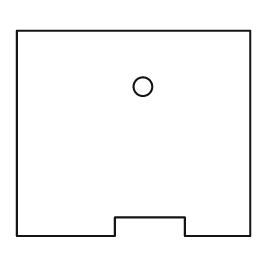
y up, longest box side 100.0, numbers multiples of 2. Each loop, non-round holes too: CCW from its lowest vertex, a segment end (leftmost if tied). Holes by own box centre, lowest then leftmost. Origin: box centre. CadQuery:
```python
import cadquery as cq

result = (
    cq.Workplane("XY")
    .moveTo(-50.0, -44.0)
    .lineTo(-8.0, -44.0)
    .lineTo(-8.0, -36.0)
    .lineTo(22.0, -36.0)
    .lineTo(22.0, -44.0)
    .lineTo(50.0, -44.0)
    .lineTo(50.0, 44.0)
    .lineTo(-50.0, 44.0)
    .close()
    .moveTo(4.0, 20.0)
    .circle(4.0)
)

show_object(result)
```